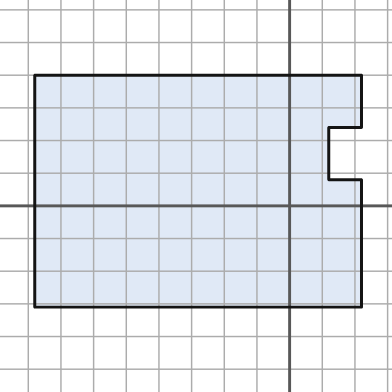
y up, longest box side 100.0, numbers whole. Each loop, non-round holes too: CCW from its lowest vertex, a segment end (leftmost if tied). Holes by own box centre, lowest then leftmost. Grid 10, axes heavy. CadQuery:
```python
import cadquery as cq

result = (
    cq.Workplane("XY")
    .moveTo(-78.0, -31.0)
    .lineTo(22.0, -31.0)
    .lineTo(22.0, 8.0)
    .lineTo(12.0, 8.0)
    .lineTo(12.0, 24.0)
    .lineTo(22.0, 24.0)
    .lineTo(22.0, 40.0)
    .lineTo(-78.0, 40.0)
    .close()
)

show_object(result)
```